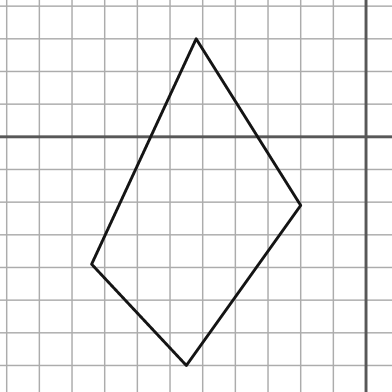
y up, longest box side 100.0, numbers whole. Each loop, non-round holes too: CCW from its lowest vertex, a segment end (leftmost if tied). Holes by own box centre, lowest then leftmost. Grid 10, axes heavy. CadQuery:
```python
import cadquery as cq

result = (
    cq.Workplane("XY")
    .moveTo(-55.0, -70.0)
    .lineTo(-20.0, -21.0)
    .lineTo(-52.0, 30.0)
    .lineTo(-84.0, -39.0)
    .close()
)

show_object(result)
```